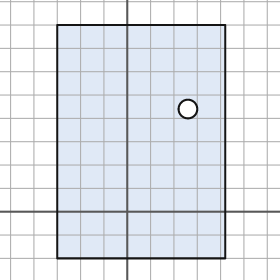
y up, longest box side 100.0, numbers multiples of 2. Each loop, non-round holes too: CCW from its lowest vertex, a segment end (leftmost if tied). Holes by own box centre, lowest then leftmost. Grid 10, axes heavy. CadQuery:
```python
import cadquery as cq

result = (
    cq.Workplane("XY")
    .moveTo(-30.0, -20.0)
    .lineTo(42.0, -20.0)
    .lineTo(42.0, 80.0)
    .lineTo(-30.0, 80.0)
    .close()
    .moveTo(26.0, 44.0)
    .circle(4.0)
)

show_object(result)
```